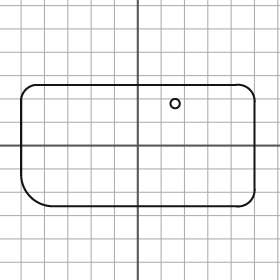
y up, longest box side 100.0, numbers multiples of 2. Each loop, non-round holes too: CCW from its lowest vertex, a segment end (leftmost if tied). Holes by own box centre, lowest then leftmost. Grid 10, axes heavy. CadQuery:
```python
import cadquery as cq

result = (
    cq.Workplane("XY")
    .moveTo(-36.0, -26.0)
    .lineTo(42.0, -26.0)
    .threePointArc((48.0, -24.0), (50.0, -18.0))
    .lineTo(50.0, 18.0)
    .threePointArc((48.0, 24.0), (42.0, 26.0))
    .lineTo(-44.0, 26.0)
    .threePointArc((-48.0, 24.0), (-50.0, 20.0))
    .lineTo(-50.0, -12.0)
    .threePointArc((-46.0, -22.0), (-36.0, -26.0))
    .close()
    .moveTo(16.0, 18.0)
    .circle(2.0)
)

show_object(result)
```